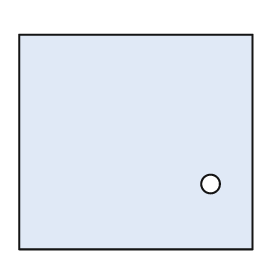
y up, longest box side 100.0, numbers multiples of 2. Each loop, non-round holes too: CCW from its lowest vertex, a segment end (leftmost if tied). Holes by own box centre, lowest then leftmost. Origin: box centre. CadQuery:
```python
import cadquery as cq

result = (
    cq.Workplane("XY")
    .moveTo(-50.0, -46.0)
    .lineTo(50.0, -46.0)
    .lineTo(50.0, 46.0)
    .lineTo(-50.0, 46.0)
    .close()
    .moveTo(32.0, -18.0)
    .circle(4.0)
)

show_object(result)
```